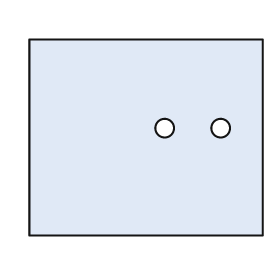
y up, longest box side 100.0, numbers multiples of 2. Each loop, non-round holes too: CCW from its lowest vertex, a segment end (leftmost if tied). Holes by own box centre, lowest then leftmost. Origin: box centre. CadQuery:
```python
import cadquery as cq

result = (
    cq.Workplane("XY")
    .moveTo(-50.0, -42.0)
    .lineTo(50.0, -42.0)
    .lineTo(50.0, 42.0)
    .lineTo(-50.0, 42.0)
    .close()
    .moveTo(8.0, 4.0)
    .circle(4.0)
    .moveTo(32.0, 4.0)
    .circle(4.0)
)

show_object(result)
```